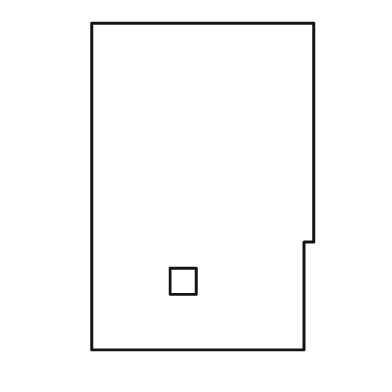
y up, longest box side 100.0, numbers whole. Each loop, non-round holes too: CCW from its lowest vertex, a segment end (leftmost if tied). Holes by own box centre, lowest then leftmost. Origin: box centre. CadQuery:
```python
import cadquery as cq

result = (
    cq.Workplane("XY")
    .moveTo(-34.0, -50.0)
    .lineTo(31.0, -50.0)
    .lineTo(31.0, -17.0)
    .lineTo(34.0, -17.0)
    .lineTo(34.0, 50.0)
    .lineTo(-34.0, 50.0)
    .close()
    .moveTo(-10.0, -33.0)
    .lineTo(-2.0, -33.0)
    .lineTo(-2.0, -25.0)
    .lineTo(-10.0, -25.0)
    .close()
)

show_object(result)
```